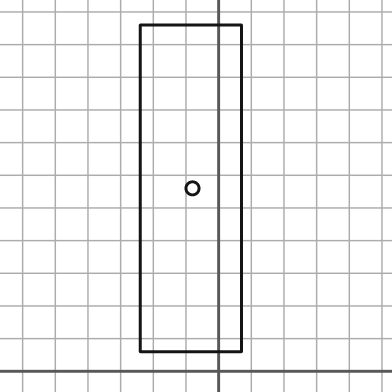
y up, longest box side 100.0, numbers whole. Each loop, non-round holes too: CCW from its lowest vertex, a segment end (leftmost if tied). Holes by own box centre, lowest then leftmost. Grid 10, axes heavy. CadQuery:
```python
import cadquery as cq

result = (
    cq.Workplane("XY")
    .moveTo(-24.0, 6.0)
    .lineTo(7.0, 6.0)
    .lineTo(7.0, 106.0)
    .lineTo(-24.0, 106.0)
    .close()
    .moveTo(-8.0, 56.0)
    .circle(2.0)
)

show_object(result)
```